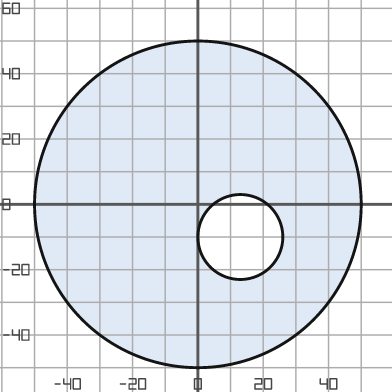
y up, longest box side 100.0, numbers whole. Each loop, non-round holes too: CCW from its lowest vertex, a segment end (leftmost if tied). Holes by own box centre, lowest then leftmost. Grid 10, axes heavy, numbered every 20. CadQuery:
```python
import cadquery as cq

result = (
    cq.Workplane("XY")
    .moveTo(0.0, 0.0)
    .circle(50.0)
    .moveTo(13.0, -10.0)
    .circle(13.0)
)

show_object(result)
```